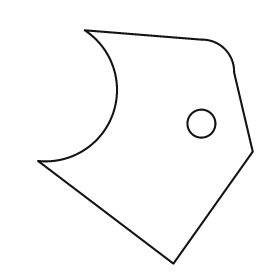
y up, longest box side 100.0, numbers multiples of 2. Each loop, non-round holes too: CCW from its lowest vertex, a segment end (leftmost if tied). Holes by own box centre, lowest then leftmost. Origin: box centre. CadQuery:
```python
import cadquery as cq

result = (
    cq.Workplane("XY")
    .moveTo(12.0, -50.0)
    .lineTo(46.0, -2.0)
    .lineTo(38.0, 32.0)
    .threePointArc((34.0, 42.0), (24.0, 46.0))
    .lineTo(-26.0, 50.0)
    .threePointArc((-14.0, 14.0), (-46.0, -6.0))
    .close()
    .moveTo(24.0, 10.0)
    .circle(6.0)
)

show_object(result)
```